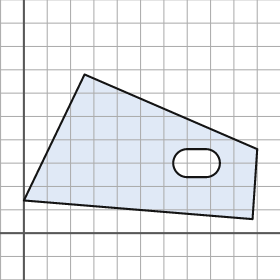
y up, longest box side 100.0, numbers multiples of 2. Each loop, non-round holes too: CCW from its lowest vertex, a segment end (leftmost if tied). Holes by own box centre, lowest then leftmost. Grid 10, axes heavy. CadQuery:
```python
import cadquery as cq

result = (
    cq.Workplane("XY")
    .moveTo(98.0, 6.0)
    .lineTo(100.0, 36.0)
    .lineTo(26.0, 68.0)
    .lineTo(0.0, 14.0)
    .close()
    .moveTo(70.0, 24.0)
    .lineTo(78.0, 24.0)
    .threePointArc((84.0, 30.0), (78.0, 36.0))
    .lineTo(70.0, 36.0)
    .threePointArc((64.0, 30.0), (70.0, 24.0))
    .close()
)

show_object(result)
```